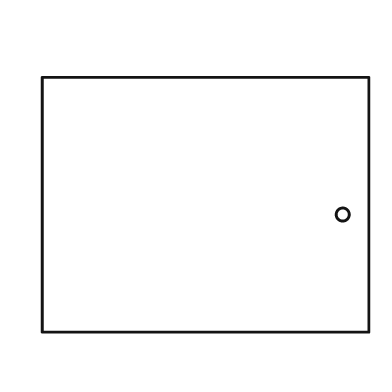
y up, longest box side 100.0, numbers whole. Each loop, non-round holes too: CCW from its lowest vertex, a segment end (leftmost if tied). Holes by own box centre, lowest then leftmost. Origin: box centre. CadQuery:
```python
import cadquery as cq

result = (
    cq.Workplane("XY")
    .moveTo(-50.0, -39.0)
    .lineTo(50.0, -39.0)
    .lineTo(50.0, 39.0)
    .lineTo(-50.0, 39.0)
    .close()
    .moveTo(42.0, -3.0)
    .circle(2.0)
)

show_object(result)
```